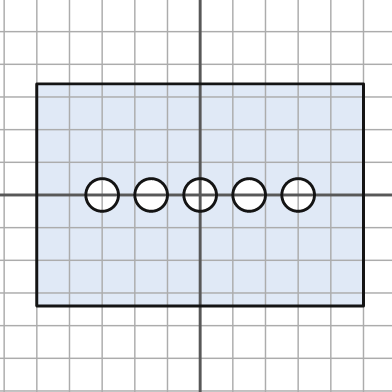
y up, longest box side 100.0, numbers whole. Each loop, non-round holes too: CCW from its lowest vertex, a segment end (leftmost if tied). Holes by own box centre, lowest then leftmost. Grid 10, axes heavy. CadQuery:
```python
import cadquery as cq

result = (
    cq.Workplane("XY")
    .moveTo(-50.0, -34.0)
    .lineTo(50.0, -34.0)
    .lineTo(50.0, 34.0)
    .lineTo(-50.0, 34.0)
    .close()
    .moveTo(-30.0, 0.0)
    .circle(5.0)
    .moveTo(-15.0, 0.0)
    .circle(5.0)
    .moveTo(0.0, 0.0)
    .circle(5.0)
    .moveTo(15.0, 0.0)
    .circle(5.0)
    .moveTo(30.0, 0.0)
    .circle(5.0)
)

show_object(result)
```